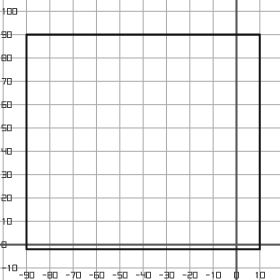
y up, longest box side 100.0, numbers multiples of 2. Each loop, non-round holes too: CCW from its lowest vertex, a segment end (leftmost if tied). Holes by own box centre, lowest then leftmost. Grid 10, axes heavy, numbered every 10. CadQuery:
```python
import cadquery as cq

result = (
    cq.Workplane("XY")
    .moveTo(-90.0, -2.0)
    .lineTo(10.0, -2.0)
    .lineTo(10.0, 90.0)
    .lineTo(-90.0, 90.0)
    .close()
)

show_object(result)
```